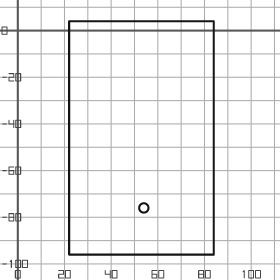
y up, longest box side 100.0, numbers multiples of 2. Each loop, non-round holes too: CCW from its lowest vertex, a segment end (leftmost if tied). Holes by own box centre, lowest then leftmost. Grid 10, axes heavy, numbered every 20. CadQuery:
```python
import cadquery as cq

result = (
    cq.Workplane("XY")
    .moveTo(22.0, -96.0)
    .lineTo(84.0, -96.0)
    .lineTo(84.0, 4.0)
    .lineTo(22.0, 4.0)
    .close()
    .moveTo(54.0, -76.0)
    .circle(2.0)
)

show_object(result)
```